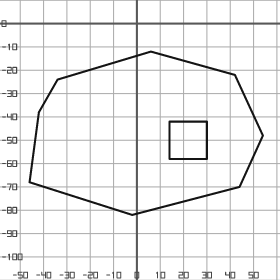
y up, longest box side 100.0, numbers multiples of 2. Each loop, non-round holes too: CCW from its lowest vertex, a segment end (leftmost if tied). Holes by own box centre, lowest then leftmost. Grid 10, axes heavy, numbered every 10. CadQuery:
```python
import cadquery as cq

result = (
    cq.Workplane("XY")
    .moveTo(-2.0, -82.0)
    .lineTo(44.0, -70.0)
    .lineTo(54.0, -48.0)
    .lineTo(42.0, -22.0)
    .lineTo(6.0, -12.0)
    .lineTo(-34.0, -24.0)
    .lineTo(-42.0, -38.0)
    .lineTo(-46.0, -68.0)
    .close()
    .moveTo(14.0, -58.0)
    .lineTo(30.0, -58.0)
    .lineTo(30.0, -42.0)
    .lineTo(14.0, -42.0)
    .close()
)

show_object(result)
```